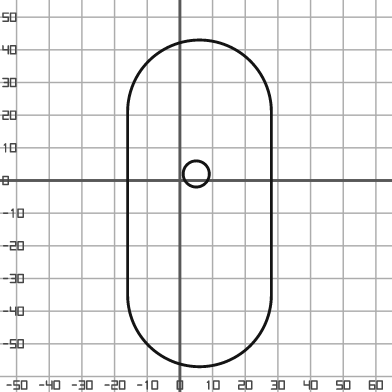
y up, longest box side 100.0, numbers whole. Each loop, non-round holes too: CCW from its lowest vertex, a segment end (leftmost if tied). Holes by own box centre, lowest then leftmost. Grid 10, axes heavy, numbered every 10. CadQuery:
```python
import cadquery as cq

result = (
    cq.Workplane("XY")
    .moveTo(-16.0, -35.0)
    .threePointArc((6.0, -57.0), (28.0, -35.0))
    .lineTo(28.0, 21.0)
    .threePointArc((6.0, 43.0), (-16.0, 21.0))
    .close()
    .moveTo(5.0, 2.0)
    .circle(4.0)
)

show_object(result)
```